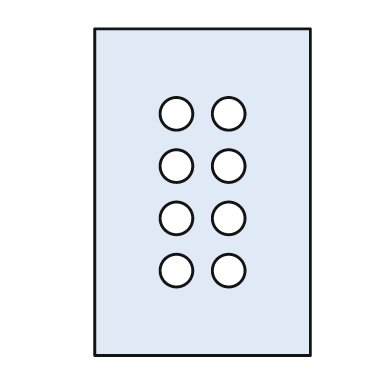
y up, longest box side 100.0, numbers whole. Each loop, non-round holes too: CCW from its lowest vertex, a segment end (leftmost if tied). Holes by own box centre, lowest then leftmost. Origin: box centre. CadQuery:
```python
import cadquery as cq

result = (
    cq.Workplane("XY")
    .moveTo(-33.0, -50.0)
    .lineTo(33.0, -50.0)
    .lineTo(33.0, 50.0)
    .lineTo(-33.0, 50.0)
    .close()
    .moveTo(-8.0, -24.0)
    .circle(5.0)
    .moveTo(8.0, -24.0)
    .circle(5.0)
    .moveTo(-8.0, -8.0)
    .circle(5.0)
    .moveTo(8.0, -8.0)
    .circle(5.0)
    .moveTo(-8.0, 8.0)
    .circle(5.0)
    .moveTo(8.0, 8.0)
    .circle(5.0)
    .moveTo(-8.0, 24.0)
    .circle(5.0)
    .moveTo(8.0, 24.0)
    .circle(5.0)
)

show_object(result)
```